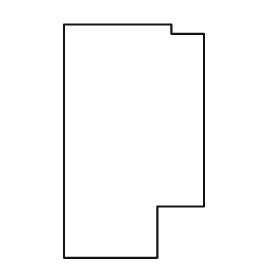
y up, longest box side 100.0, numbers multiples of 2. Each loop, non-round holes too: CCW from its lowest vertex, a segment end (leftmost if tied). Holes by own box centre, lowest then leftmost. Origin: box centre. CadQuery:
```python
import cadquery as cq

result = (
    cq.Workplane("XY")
    .moveTo(-30.0, -50.0)
    .lineTo(10.0, -50.0)
    .lineTo(10.0, -28.0)
    .lineTo(30.0, -28.0)
    .lineTo(30.0, 46.0)
    .lineTo(16.0, 46.0)
    .lineTo(16.0, 50.0)
    .lineTo(-30.0, 50.0)
    .close()
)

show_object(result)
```